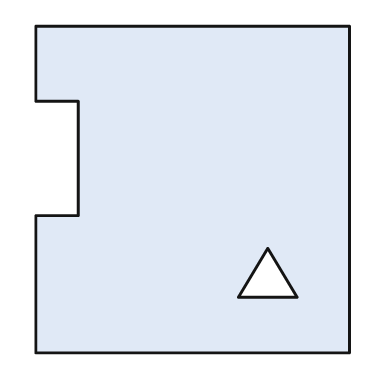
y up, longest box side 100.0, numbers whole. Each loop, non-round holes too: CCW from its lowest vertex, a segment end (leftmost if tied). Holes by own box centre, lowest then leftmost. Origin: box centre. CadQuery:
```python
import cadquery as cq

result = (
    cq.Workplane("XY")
    .moveTo(-48.0, -50.0)
    .lineTo(48.0, -50.0)
    .lineTo(48.0, 50.0)
    .lineTo(-48.0, 50.0)
    .lineTo(-48.0, 27.0)
    .lineTo(-35.0, 27.0)
    .lineTo(-35.0, -8.0)
    .lineTo(-48.0, -8.0)
    .close()
    .moveTo(14.0, -33.0)
    .lineTo(32.0, -33.0)
    .lineTo(23.0, -18.0)
    .close()
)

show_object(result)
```